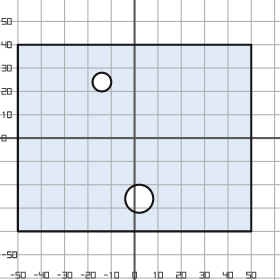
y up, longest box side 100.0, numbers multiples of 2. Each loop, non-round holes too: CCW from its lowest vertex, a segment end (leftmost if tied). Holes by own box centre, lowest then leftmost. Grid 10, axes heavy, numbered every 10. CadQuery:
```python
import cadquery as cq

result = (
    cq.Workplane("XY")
    .moveTo(-50.0, -40.0)
    .lineTo(50.0, -40.0)
    .lineTo(50.0, 40.0)
    .lineTo(-50.0, 40.0)
    .close()
    .moveTo(2.0, -26.0)
    .circle(6.0)
    .moveTo(-14.0, 24.0)
    .circle(4.0)
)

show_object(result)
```